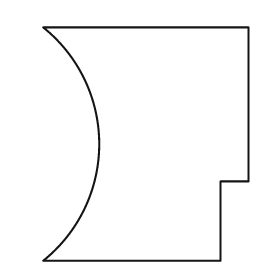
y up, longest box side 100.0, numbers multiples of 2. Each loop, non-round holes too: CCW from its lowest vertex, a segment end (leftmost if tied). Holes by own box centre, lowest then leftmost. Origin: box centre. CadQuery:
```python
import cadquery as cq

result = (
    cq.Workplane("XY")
    .moveTo(-44.0, -50.0)
    .lineTo(32.0, -50.0)
    .lineTo(32.0, -16.0)
    .lineTo(44.0, -16.0)
    .lineTo(44.0, 50.0)
    .lineTo(-44.0, 50.0)
    .threePointArc((-20.0, 0.0), (-44.0, -50.0))
    .close()
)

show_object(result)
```